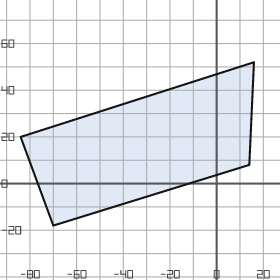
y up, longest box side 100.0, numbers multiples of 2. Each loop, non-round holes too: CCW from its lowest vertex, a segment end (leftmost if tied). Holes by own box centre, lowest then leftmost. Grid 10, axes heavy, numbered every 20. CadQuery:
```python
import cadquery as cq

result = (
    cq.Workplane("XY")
    .moveTo(-70.0, -18.0)
    .lineTo(14.0, 8.0)
    .lineTo(16.0, 52.0)
    .lineTo(-84.0, 20.0)
    .close()
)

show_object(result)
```